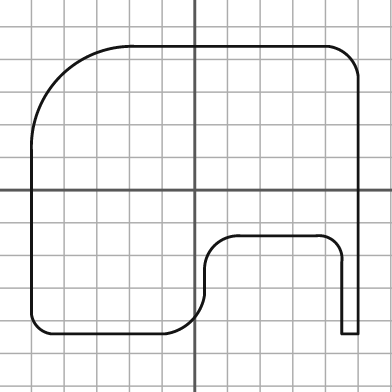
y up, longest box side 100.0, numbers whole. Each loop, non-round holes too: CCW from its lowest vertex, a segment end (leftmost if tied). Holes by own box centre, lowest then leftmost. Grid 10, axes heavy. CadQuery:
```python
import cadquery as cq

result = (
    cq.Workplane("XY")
    .moveTo(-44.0, -44.0)
    .lineTo(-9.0, -44.0)
    .threePointArc((-1.0, -40.0), (3.0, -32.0))
    .lineTo(3.0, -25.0)
    .threePointArc((6.0, -17.0), (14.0, -14.0))
    .lineTo(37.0, -14.0)
    .threePointArc((43.0, -16.0), (45.0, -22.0))
    .lineTo(45.0, -44.0)
    .lineTo(50.0, -44.0)
    .lineTo(50.0, 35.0)
    .threePointArc((47.0, 41.0), (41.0, 44.0))
    .lineTo(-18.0, 44.0)
    .threePointArc((-41.0, 35.0), (-50.0, 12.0))
    .lineTo(-50.0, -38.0)
    .threePointArc((-48.0, -42.0), (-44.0, -44.0))
    .close()
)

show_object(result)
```